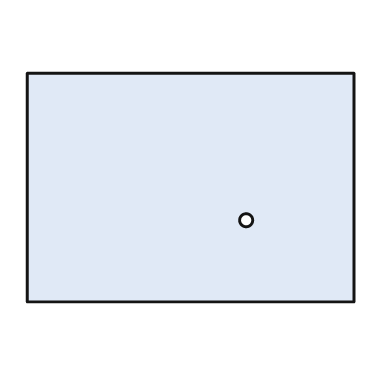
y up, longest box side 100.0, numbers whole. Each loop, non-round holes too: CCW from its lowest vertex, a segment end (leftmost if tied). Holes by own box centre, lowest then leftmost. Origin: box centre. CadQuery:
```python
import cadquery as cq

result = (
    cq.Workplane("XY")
    .moveTo(-50.0, -35.0)
    .lineTo(50.0, -35.0)
    .lineTo(50.0, 35.0)
    .lineTo(-50.0, 35.0)
    .close()
    .moveTo(17.0, -10.0)
    .circle(2.0)
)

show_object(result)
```